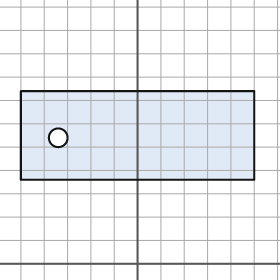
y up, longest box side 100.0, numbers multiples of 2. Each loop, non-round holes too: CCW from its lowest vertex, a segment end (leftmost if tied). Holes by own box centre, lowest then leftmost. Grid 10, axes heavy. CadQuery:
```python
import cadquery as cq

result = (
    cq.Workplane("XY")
    .moveTo(-50.0, 36.0)
    .lineTo(50.0, 36.0)
    .lineTo(50.0, 74.0)
    .lineTo(-50.0, 74.0)
    .close()
    .moveTo(-34.0, 54.0)
    .circle(4.0)
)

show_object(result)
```